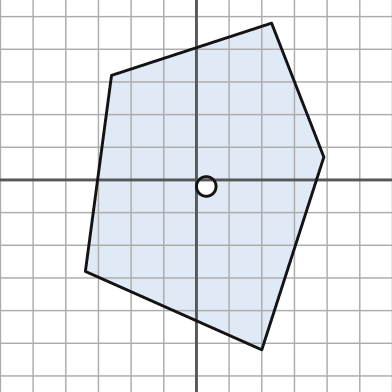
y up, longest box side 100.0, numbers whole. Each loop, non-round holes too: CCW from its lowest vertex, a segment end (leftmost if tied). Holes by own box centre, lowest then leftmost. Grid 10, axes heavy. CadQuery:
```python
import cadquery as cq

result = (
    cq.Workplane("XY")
    .moveTo(20.0, -52.0)
    .lineTo(39.0, 7.0)
    .lineTo(23.0, 48.0)
    .lineTo(-26.0, 32.0)
    .lineTo(-34.0, -28.0)
    .close()
    .moveTo(3.0, -2.0)
    .circle(3.0)
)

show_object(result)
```